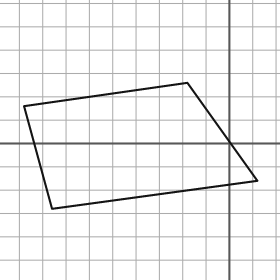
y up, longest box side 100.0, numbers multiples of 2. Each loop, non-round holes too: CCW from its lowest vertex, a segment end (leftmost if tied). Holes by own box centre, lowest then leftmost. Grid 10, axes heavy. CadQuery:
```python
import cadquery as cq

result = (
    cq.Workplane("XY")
    .moveTo(-76.0, -28.0)
    .lineTo(12.0, -16.0)
    .lineTo(-18.0, 26.0)
    .lineTo(-88.0, 16.0)
    .close()
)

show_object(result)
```